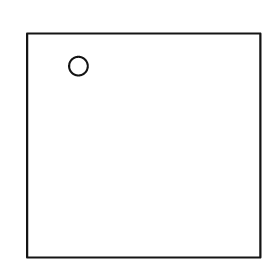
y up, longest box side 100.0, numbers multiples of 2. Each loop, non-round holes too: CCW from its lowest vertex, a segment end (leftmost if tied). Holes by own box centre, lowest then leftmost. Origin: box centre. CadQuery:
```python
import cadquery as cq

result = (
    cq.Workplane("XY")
    .moveTo(-50.0, -48.0)
    .lineTo(50.0, -48.0)
    .lineTo(50.0, 48.0)
    .lineTo(-50.0, 48.0)
    .close()
    .moveTo(-28.0, 34.0)
    .circle(4.0)
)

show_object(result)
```